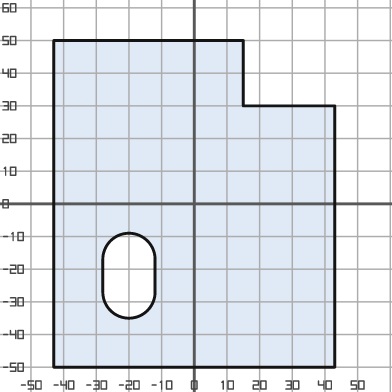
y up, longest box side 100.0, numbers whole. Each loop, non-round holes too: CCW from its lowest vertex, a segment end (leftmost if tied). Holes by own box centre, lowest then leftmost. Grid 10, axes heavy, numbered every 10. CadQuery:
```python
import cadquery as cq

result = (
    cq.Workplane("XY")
    .moveTo(-43.0, -50.0)
    .lineTo(43.0, -50.0)
    .lineTo(43.0, 30.0)
    .lineTo(15.0, 30.0)
    .lineTo(15.0, 50.0)
    .lineTo(-43.0, 50.0)
    .close()
    .moveTo(-28.0, -27.0)
    .threePointArc((-20.0, -35.0), (-12.0, -27.0))
    .lineTo(-12.0, -17.0)
    .threePointArc((-20.0, -9.0), (-28.0, -17.0))
    .close()
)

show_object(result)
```